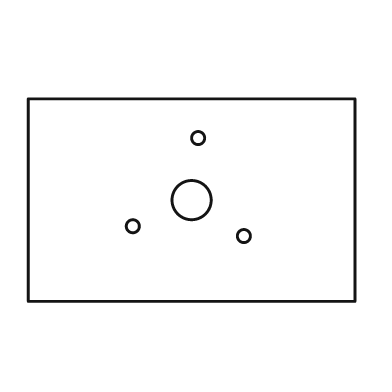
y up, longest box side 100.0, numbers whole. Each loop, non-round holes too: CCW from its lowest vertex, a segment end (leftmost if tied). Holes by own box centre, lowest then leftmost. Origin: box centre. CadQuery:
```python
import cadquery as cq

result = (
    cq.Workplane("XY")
    .moveTo(-50.0, -31.0)
    .lineTo(50.0, -31.0)
    .lineTo(50.0, 31.0)
    .lineTo(-50.0, 31.0)
    .close()
    .moveTo(16.0, -11.0)
    .circle(2.0)
    .moveTo(-18.0, -8.0)
    .circle(2.0)
    .moveTo(0.0, 0.0)
    .circle(6.0)
    .moveTo(2.0, 19.0)
    .circle(2.0)
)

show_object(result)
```